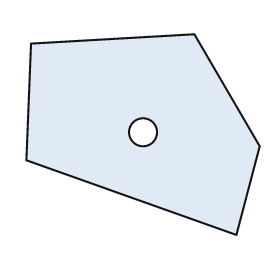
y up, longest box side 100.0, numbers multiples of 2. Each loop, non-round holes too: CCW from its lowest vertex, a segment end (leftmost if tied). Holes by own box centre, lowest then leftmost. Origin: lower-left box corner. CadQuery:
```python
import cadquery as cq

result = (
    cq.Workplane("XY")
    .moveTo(90.0, 0.0)
    .lineTo(100.0, 38.0)
    .lineTo(72.0, 86.0)
    .lineTo(2.0, 82.0)
    .lineTo(0.0, 32.0)
    .close()
    .moveTo(50.0, 44.0)
    .circle(6.0)
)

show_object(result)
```